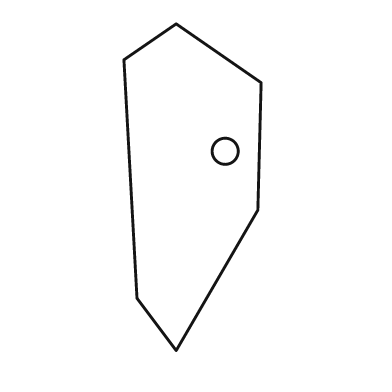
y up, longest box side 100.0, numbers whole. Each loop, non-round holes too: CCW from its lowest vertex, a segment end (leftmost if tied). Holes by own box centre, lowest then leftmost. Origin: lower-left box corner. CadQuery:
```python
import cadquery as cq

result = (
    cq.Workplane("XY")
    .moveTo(16.0, 0.0)
    .lineTo(41.0, 43.0)
    .lineTo(42.0, 82.0)
    .lineTo(16.0, 100.0)
    .lineTo(0.0, 89.0)
    .lineTo(4.0, 16.0)
    .close()
    .moveTo(31.0, 61.0)
    .circle(4.0)
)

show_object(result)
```